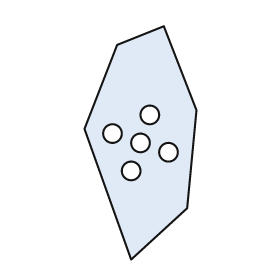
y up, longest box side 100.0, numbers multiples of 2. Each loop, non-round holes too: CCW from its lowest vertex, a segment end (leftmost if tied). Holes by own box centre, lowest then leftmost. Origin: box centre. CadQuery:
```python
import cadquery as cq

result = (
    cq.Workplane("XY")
    .moveTo(-4.0, -50.0)
    .lineTo(20.0, -28.0)
    .lineTo(24.0, 14.0)
    .lineTo(10.0, 50.0)
    .lineTo(-10.0, 42.0)
    .lineTo(-24.0, 6.0)
    .close()
    .moveTo(-4.0, -12.0)
    .circle(4.0)
    .moveTo(12.0, -4.0)
    .circle(4.0)
    .moveTo(0.0, 0.0)
    .circle(4.0)
    .moveTo(-12.0, 4.0)
    .circle(4.0)
    .moveTo(4.0, 12.0)
    .circle(4.0)
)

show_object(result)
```